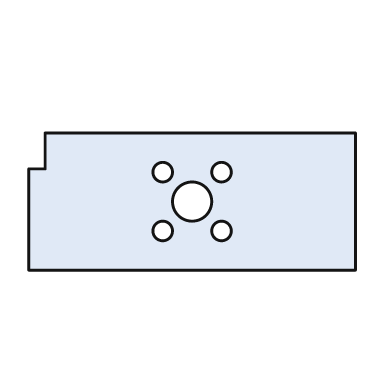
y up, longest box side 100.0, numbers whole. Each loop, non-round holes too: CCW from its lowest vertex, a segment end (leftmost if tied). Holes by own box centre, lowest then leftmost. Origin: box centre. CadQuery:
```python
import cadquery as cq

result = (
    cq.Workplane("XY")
    .moveTo(-50.0, -21.0)
    .lineTo(50.0, -21.0)
    .lineTo(50.0, 21.0)
    .lineTo(-45.0, 21.0)
    .lineTo(-45.0, 10.0)
    .lineTo(-50.0, 10.0)
    .close()
    .moveTo(-9.0, -9.0)
    .circle(3.0)
    .moveTo(9.0, -9.0)
    .circle(3.0)
    .moveTo(0.0, 0.0)
    .circle(6.0)
    .moveTo(-9.0, 9.0)
    .circle(3.0)
    .moveTo(9.0, 9.0)
    .circle(3.0)
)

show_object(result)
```